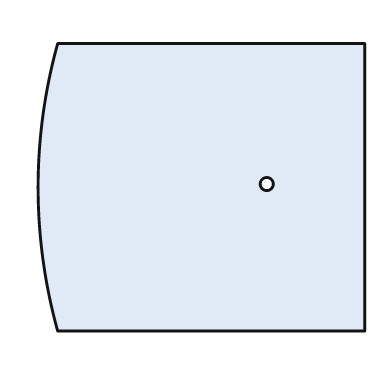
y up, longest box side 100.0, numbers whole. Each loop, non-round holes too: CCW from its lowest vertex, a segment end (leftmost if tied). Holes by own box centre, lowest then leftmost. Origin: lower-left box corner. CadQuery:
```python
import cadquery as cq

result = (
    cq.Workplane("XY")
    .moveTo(6.0, 0.0)
    .lineTo(100.0, 0.0)
    .lineTo(100.0, 88.0)
    .lineTo(6.0, 88.0)
    .threePointArc((0.0, 44.0), (6.0, 0.0))
    .close()
    .moveTo(70.0, 45.0)
    .circle(2.0)
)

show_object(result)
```